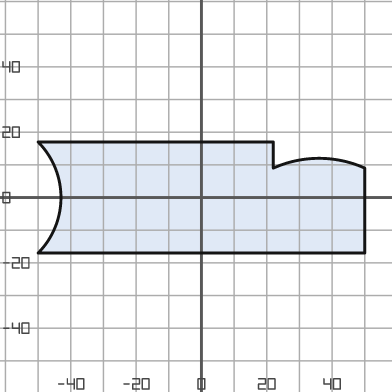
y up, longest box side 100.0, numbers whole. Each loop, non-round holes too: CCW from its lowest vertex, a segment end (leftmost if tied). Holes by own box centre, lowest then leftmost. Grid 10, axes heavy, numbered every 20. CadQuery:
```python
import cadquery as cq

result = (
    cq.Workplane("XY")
    .moveTo(-50.0, -17.0)
    .lineTo(50.0, -17.0)
    .lineTo(50.0, 9.0)
    .threePointArc((36.0, 12.0), (22.0, 9.0))
    .lineTo(22.0, 17.0)
    .lineTo(-50.0, 17.0)
    .threePointArc((-43.0, 0.0), (-50.0, -17.0))
    .close()
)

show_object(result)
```